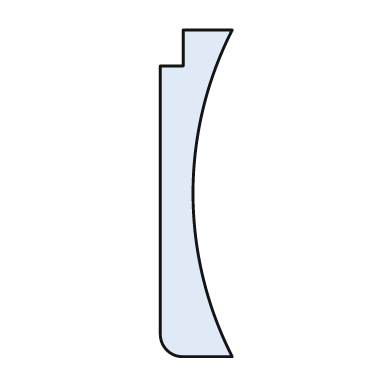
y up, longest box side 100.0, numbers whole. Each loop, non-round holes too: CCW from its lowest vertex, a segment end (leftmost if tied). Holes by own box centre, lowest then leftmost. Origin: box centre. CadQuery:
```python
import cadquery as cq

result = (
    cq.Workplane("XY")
    .moveTo(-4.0, -50.0)
    .lineTo(11.0, -50.0)
    .threePointArc((-1.0, 0.0), (11.0, 50.0))
    .lineTo(-4.0, 50.0)
    .lineTo(-4.0, 39.0)
    .lineTo(-11.0, 39.0)
    .lineTo(-11.0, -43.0)
    .threePointArc((-9.0, -48.0), (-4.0, -50.0))
    .close()
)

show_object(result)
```